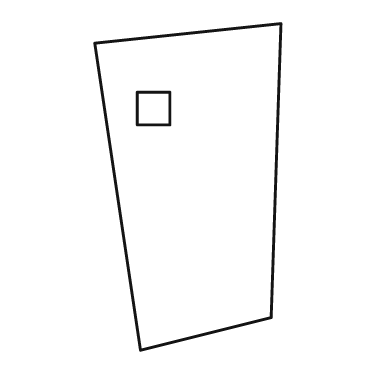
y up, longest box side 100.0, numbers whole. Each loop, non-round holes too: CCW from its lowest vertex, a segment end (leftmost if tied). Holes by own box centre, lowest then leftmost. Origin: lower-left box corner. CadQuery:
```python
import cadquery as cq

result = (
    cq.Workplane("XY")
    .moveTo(14.0, 0.0)
    .lineTo(54.0, 10.0)
    .lineTo(57.0, 100.0)
    .lineTo(0.0, 94.0)
    .close()
    .moveTo(13.0, 69.0)
    .lineTo(23.0, 69.0)
    .lineTo(23.0, 79.0)
    .lineTo(13.0, 79.0)
    .close()
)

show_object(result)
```